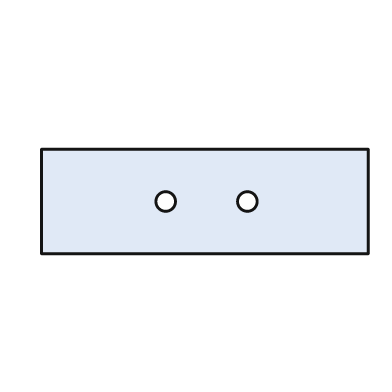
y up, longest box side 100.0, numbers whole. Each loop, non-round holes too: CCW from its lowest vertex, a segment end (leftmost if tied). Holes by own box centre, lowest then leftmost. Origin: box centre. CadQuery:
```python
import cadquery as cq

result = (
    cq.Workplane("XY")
    .moveTo(-50.0, -16.0)
    .lineTo(50.0, -16.0)
    .lineTo(50.0, 16.0)
    .lineTo(-50.0, 16.0)
    .close()
    .moveTo(-12.0, 0.0)
    .circle(3.0)
    .moveTo(13.0, 0.0)
    .circle(3.0)
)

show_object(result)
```